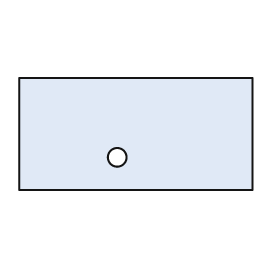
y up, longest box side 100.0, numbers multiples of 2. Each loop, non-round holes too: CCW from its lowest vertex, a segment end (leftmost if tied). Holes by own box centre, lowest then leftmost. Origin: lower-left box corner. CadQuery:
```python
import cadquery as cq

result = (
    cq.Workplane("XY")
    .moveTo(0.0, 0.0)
    .lineTo(100.0, 0.0)
    .lineTo(100.0, 48.0)
    .lineTo(0.0, 48.0)
    .close()
    .moveTo(42.0, 14.0)
    .circle(4.0)
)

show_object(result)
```